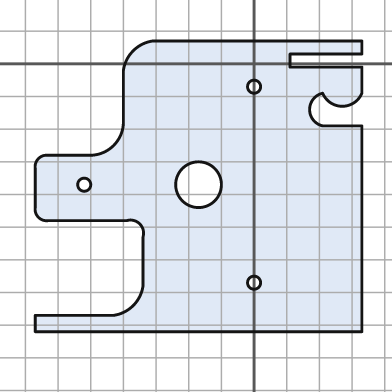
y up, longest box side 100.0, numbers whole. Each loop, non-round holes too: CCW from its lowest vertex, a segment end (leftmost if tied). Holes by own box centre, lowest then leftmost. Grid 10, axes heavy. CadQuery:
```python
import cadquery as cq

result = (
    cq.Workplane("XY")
    .moveTo(-67.0, -82.0)
    .lineTo(33.0, -82.0)
    .lineTo(33.0, -19.0)
    .lineTo(21.0, -19.0)
    .threePointArc((17.0, -14.0), (21.0, -9.0))
    .threePointArc((27.0, -13.0), (33.0, -9.0))
    .lineTo(33.0, -1.0)
    .lineTo(11.0, -1.0)
    .lineTo(11.0, 3.0)
    .lineTo(33.0, 3.0)
    .lineTo(33.0, 7.0)
    .lineTo(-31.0, 7.0)
    .threePointArc((-37.0, 4.0), (-40.0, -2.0))
    .lineTo(-40.0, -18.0)
    .threePointArc((-43.0, -25.0), (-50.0, -28.0))
    .lineTo(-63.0, -28.0)
    .threePointArc((-66.0, -29.0), (-67.0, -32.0))
    .lineTo(-67.0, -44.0)
    .threePointArc((-66.0, -47.0), (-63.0, -48.0))
    .lineTo(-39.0, -48.0)
    .threePointArc((-35.0, -49.0), (-34.0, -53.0))
    .lineTo(-34.0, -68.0)
    .threePointArc((-37.0, -74.0), (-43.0, -77.0))
    .lineTo(-67.0, -77.0)
    .close()
    .moveTo(0.0, -67.0)
    .circle(2.0)
    .moveTo(-52.0, -37.0)
    .circle(2.0)
    .moveTo(-17.0, -37.0)
    .circle(7.0)
    .moveTo(0.0, -7.0)
    .circle(2.0)
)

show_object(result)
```